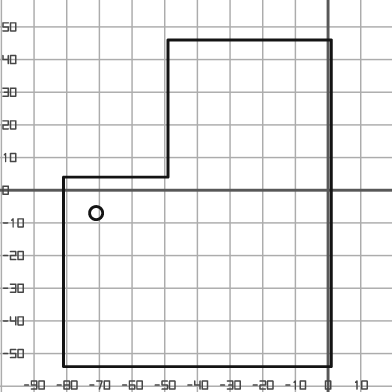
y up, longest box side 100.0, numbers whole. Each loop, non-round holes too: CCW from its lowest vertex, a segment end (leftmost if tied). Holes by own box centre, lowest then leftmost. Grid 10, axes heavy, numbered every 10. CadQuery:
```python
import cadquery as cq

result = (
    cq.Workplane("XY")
    .moveTo(-81.0, -54.0)
    .lineTo(1.0, -54.0)
    .lineTo(1.0, 46.0)
    .lineTo(-49.0, 46.0)
    .lineTo(-49.0, 4.0)
    .lineTo(-81.0, 4.0)
    .close()
    .moveTo(-71.0, -7.0)
    .circle(2.0)
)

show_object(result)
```